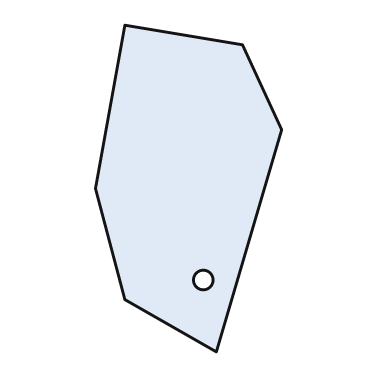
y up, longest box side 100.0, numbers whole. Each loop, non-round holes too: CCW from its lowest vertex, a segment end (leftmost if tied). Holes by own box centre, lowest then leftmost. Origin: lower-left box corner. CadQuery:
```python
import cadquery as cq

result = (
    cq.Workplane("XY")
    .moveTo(37.0, 0.0)
    .lineTo(57.0, 68.0)
    .lineTo(45.0, 94.0)
    .lineTo(9.0, 100.0)
    .lineTo(0.0, 50.0)
    .lineTo(9.0, 16.0)
    .close()
    .moveTo(33.0, 22.0)
    .circle(3.0)
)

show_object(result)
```